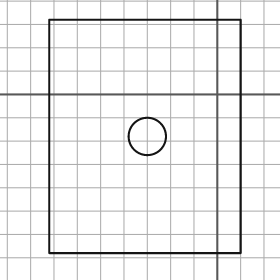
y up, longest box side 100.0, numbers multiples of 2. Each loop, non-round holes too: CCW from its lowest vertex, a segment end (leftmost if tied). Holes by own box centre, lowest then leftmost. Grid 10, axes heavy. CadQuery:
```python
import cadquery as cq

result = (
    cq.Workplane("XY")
    .moveTo(-72.0, -68.0)
    .lineTo(10.0, -68.0)
    .lineTo(10.0, 32.0)
    .lineTo(-72.0, 32.0)
    .close()
    .moveTo(-30.0, -18.0)
    .circle(8.0)
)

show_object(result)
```